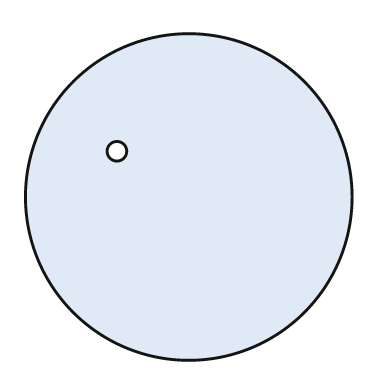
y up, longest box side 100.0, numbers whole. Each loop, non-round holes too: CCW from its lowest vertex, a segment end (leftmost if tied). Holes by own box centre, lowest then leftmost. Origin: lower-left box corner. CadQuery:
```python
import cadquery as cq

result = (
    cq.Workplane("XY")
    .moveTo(50.0, 50.0)
    .circle(50.0)
    .moveTo(28.0, 64.0)
    .circle(3.0)
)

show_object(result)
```